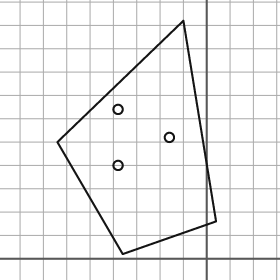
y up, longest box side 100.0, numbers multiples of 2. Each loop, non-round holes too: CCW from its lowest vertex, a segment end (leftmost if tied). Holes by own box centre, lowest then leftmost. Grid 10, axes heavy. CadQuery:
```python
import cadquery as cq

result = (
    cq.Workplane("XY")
    .moveTo(-36.0, 2.0)
    .lineTo(4.0, 16.0)
    .lineTo(-10.0, 102.0)
    .lineTo(-64.0, 50.0)
    .close()
    .moveTo(-38.0, 40.0)
    .circle(2.0)
    .moveTo(-16.0, 52.0)
    .circle(2.0)
    .moveTo(-38.0, 64.0)
    .circle(2.0)
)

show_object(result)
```